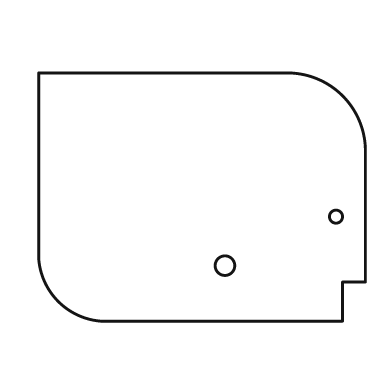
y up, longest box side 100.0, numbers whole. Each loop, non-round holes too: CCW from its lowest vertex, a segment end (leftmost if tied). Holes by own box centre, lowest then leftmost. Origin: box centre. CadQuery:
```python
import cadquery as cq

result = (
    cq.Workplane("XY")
    .moveTo(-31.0, -38.0)
    .lineTo(43.0, -38.0)
    .lineTo(43.0, -26.0)
    .lineTo(50.0, -26.0)
    .lineTo(50.0, 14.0)
    .threePointArc((43.0, 31.0), (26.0, 38.0))
    .lineTo(-50.0, 38.0)
    .lineTo(-50.0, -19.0)
    .threePointArc((-44.0, -32.0), (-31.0, -38.0))
    .close()
    .moveTo(7.0, -21.0)
    .circle(3.0)
    .moveTo(41.0, -6.0)
    .circle(2.0)
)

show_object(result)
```